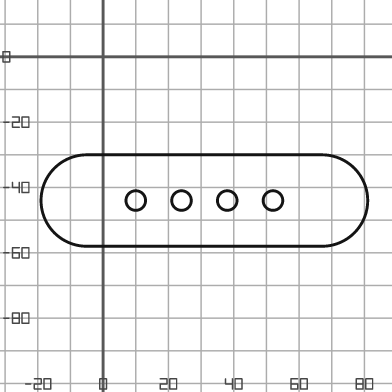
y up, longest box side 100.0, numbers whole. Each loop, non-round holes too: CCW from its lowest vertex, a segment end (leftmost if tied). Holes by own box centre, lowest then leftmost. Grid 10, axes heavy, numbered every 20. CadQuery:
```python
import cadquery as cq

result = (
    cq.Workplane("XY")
    .moveTo(-5.0, -58.0)
    .lineTo(67.0, -58.0)
    .threePointArc((81.0, -44.0), (67.0, -30.0))
    .lineTo(-5.0, -30.0)
    .threePointArc((-19.0, -44.0), (-5.0, -58.0))
    .close()
    .moveTo(10.0, -44.0)
    .circle(3.0)
    .moveTo(24.0, -44.0)
    .circle(3.0)
    .moveTo(38.0, -44.0)
    .circle(3.0)
    .moveTo(52.0, -44.0)
    .circle(3.0)
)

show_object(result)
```